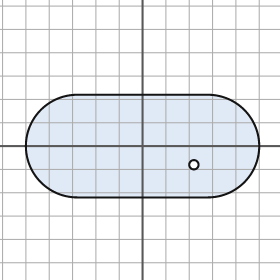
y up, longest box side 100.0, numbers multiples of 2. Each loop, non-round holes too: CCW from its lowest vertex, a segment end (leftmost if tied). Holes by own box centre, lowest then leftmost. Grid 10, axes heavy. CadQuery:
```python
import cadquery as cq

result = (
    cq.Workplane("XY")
    .moveTo(-28.0, -22.0)
    .lineTo(28.0, -22.0)
    .threePointArc((50.0, 0.0), (28.0, 22.0))
    .lineTo(-28.0, 22.0)
    .threePointArc((-50.0, 0.0), (-28.0, -22.0))
    .close()
    .moveTo(22.0, -8.0)
    .circle(2.0)
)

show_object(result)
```